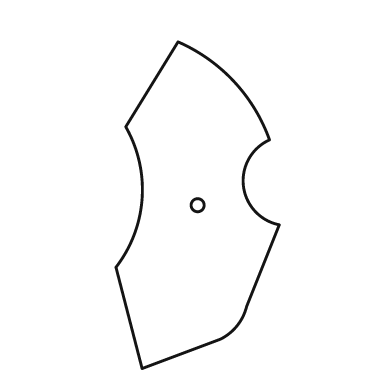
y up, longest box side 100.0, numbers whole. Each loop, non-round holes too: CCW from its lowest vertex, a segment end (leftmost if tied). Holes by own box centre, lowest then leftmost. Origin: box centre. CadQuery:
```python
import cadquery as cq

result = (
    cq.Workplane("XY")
    .moveTo(-17.0, -50.0)
    .lineTo(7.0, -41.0)
    .threePointArc((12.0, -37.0), (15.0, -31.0))
    .lineTo(25.0, -6.0)
    .threePointArc((14.0, 6.0), (22.0, 20.0))
    .threePointArc((11.0, 38.0), (-6.0, 50.0))
    .lineTo(-22.0, 24.0)
    .threePointArc((-17.0, 2.0), (-25.0, -19.0))
    .close()
    .moveTo(0.0, 0.0)
    .circle(2.0)
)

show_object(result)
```